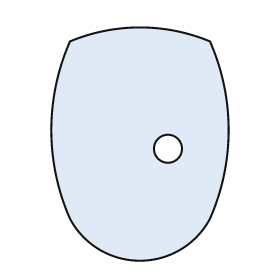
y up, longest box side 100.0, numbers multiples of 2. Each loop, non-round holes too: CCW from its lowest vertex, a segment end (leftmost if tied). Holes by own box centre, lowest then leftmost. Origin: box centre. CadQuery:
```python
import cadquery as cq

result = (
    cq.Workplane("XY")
    .moveTo(-30.0, -32.0)
    .threePointArc((0.0, -50.0), (30.0, -32.0))
    .threePointArc((38.0, 6.0), (30.0, 44.0))
    .threePointArc((0.0, 50.0), (-30.0, 44.0))
    .threePointArc((-38.0, 6.0), (-30.0, -32.0))
    .close()
    .moveTo(12.0, -2.0)
    .circle(6.0)
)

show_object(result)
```